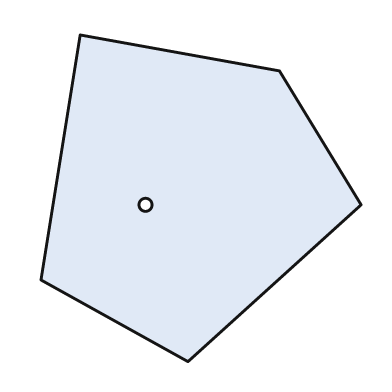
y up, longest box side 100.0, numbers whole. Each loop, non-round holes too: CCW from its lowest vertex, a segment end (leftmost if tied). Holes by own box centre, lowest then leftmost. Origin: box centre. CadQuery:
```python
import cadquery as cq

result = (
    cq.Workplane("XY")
    .moveTo(-4.0, -50.0)
    .lineTo(49.0, -2.0)
    .lineTo(24.0, 39.0)
    .lineTo(-37.0, 50.0)
    .lineTo(-49.0, -25.0)
    .close()
    .moveTo(-17.0, -2.0)
    .circle(2.0)
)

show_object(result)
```